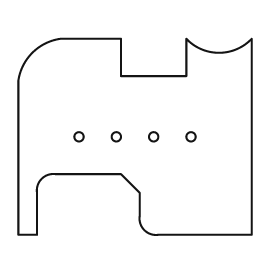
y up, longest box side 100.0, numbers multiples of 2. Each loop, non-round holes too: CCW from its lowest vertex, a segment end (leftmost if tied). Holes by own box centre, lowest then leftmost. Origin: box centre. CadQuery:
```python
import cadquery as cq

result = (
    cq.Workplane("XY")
    .moveTo(-50.0, -42.0)
    .lineTo(-42.0, -42.0)
    .lineTo(-42.0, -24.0)
    .threePointArc((-40.0, -18.0), (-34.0, -16.0))
    .lineTo(-6.0, -16.0)
    .lineTo(2.0, -24.0)
    .lineTo(2.0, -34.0)
    .threePointArc((4.0, -40.0), (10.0, -42.0))
    .lineTo(50.0, -42.0)
    .lineTo(50.0, 42.0)
    .threePointArc((36.0, 36.0), (22.0, 42.0))
    .lineTo(22.0, 26.0)
    .lineTo(-6.0, 26.0)
    .lineTo(-6.0, 42.0)
    .lineTo(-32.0, 42.0)
    .threePointArc((-44.0, 36.0), (-50.0, 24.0))
    .close()
    .moveTo(-24.0, 0.0)
    .circle(2.0)
    .moveTo(-8.0, 0.0)
    .circle(2.0)
    .moveTo(8.0, 0.0)
    .circle(2.0)
    .moveTo(24.0, 0.0)
    .circle(2.0)
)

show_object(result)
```